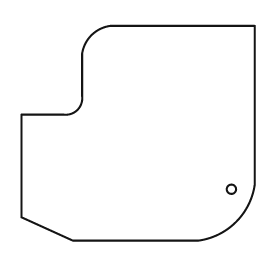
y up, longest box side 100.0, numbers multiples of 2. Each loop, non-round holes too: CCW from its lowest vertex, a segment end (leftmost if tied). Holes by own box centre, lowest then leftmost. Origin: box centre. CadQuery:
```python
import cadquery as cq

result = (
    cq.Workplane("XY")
    .moveTo(-28.0, -46.0)
    .lineTo(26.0, -46.0)
    .threePointArc((42.0, -38.0), (50.0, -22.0))
    .lineTo(50.0, 46.0)
    .lineTo(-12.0, 46.0)
    .threePointArc((-20.0, 42.0), (-24.0, 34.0))
    .lineTo(-24.0, 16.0)
    .threePointArc((-26.0, 10.0), (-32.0, 8.0))
    .lineTo(-50.0, 8.0)
    .lineTo(-50.0, -36.0)
    .close()
    .moveTo(40.0, -24.0)
    .circle(2.0)
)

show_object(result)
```